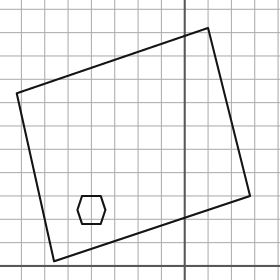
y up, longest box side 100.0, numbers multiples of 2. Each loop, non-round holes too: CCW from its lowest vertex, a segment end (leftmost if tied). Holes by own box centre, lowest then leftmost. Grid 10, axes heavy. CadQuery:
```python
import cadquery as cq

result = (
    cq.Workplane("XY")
    .moveTo(-56.0, 2.0)
    .lineTo(28.0, 30.0)
    .lineTo(10.0, 102.0)
    .lineTo(-72.0, 74.0)
    .close()
    .moveTo(-44.0, 18.0)
    .lineTo(-36.0, 18.0)
    .lineTo(-34.0, 24.0)
    .lineTo(-36.0, 30.0)
    .lineTo(-44.0, 30.0)
    .lineTo(-46.0, 24.0)
    .close()
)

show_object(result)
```